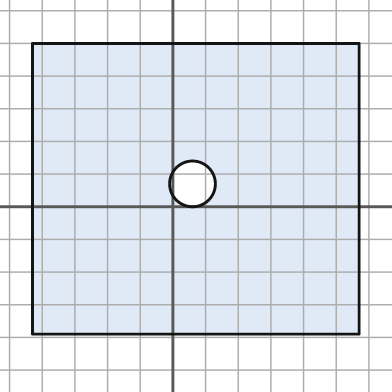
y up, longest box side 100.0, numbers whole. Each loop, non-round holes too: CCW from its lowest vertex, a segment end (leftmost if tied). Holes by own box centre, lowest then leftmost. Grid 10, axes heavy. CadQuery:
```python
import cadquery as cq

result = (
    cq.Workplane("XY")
    .moveTo(-43.0, -39.0)
    .lineTo(57.0, -39.0)
    .lineTo(57.0, 50.0)
    .lineTo(-43.0, 50.0)
    .close()
    .moveTo(6.0, 7.0)
    .circle(7.0)
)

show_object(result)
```